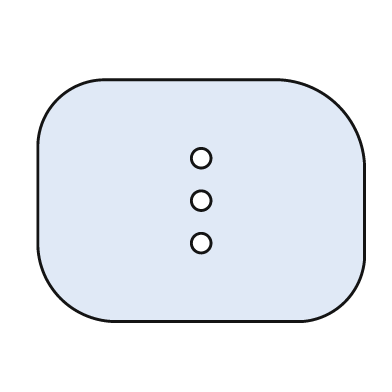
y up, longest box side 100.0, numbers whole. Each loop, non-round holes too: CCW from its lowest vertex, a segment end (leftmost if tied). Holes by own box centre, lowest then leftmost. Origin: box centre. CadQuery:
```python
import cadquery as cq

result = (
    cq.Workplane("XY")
    .moveTo(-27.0, -37.0)
    .lineTo(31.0, -37.0)
    .threePointArc((44.0, -31.0), (50.0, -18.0))
    .lineTo(50.0, 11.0)
    .threePointArc((42.0, 29.0), (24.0, 37.0))
    .lineTo(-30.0, 37.0)
    .threePointArc((-44.0, 31.0), (-50.0, 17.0))
    .lineTo(-50.0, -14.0)
    .threePointArc((-43.0, -30.0), (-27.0, -37.0))
    .close()
    .moveTo(0.0, -13.0)
    .circle(3.0)
    .moveTo(0.0, 0.0)
    .circle(3.0)
    .moveTo(0.0, 13.0)
    .circle(3.0)
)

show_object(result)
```